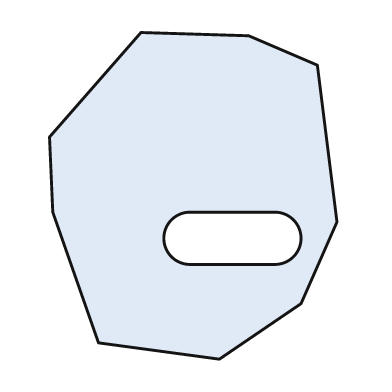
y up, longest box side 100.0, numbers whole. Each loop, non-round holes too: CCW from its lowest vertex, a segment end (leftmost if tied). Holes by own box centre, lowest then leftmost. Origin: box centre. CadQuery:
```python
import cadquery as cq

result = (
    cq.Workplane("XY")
    .moveTo(8.0, -50.0)
    .lineTo(33.0, -33.0)
    .lineTo(44.0, -8.0)
    .lineTo(38.0, 40.0)
    .lineTo(17.0, 49.0)
    .lineTo(-16.0, 50.0)
    .lineTo(-44.0, 18.0)
    .lineTo(-43.0, -5.0)
    .lineTo(-29.0, -45.0)
    .close()
    .moveTo(-1.0, -21.0)
    .lineTo(25.0, -21.0)
    .threePointArc((33.0, -13.0), (25.0, -5.0))
    .lineTo(-1.0, -5.0)
    .threePointArc((-9.0, -13.0), (-1.0, -21.0))
    .close()
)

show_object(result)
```